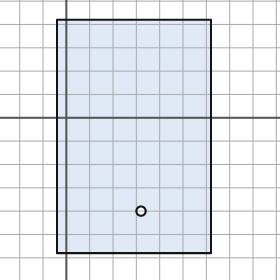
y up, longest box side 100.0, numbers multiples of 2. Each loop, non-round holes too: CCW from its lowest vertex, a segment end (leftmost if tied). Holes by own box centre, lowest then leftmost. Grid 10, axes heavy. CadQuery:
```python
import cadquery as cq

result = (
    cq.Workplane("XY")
    .moveTo(-4.0, -58.0)
    .lineTo(62.0, -58.0)
    .lineTo(62.0, 42.0)
    .lineTo(-4.0, 42.0)
    .close()
    .moveTo(32.0, -40.0)
    .circle(2.0)
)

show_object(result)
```